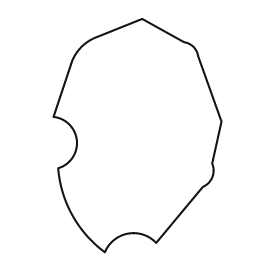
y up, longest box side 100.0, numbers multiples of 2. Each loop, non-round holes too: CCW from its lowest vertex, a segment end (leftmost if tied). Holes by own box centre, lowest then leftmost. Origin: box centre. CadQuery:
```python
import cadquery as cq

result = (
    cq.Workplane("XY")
    .moveTo(-14.0, -50.0)
    .threePointArc((-4.0, -42.0), (8.0, -46.0))
    .lineTo(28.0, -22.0)
    .threePointArc((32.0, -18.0), (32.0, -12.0))
    .lineTo(36.0, 6.0)
    .lineTo(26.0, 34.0)
    .threePointArc((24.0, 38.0), (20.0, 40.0))
    .lineTo(2.0, 50.0)
    .lineTo(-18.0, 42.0)
    .threePointArc((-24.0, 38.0), (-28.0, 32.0))
    .lineTo(-36.0, 8.0)
    .threePointArc((-26.0, -2.0), (-34.0, -14.0))
    .threePointArc((-28.0, -34.0), (-14.0, -50.0))
    .close()
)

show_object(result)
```